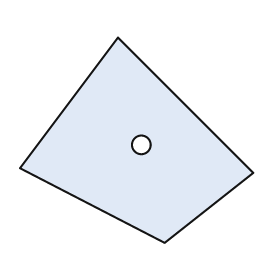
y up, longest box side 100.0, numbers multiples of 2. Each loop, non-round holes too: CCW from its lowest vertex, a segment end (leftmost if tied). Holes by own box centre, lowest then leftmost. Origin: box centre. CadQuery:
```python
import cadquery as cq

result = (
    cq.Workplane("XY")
    .moveTo(12.0, -44.0)
    .lineTo(50.0, -14.0)
    .lineTo(-8.0, 44.0)
    .lineTo(-50.0, -12.0)
    .close()
    .moveTo(2.0, -2.0)
    .circle(4.0)
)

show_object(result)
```